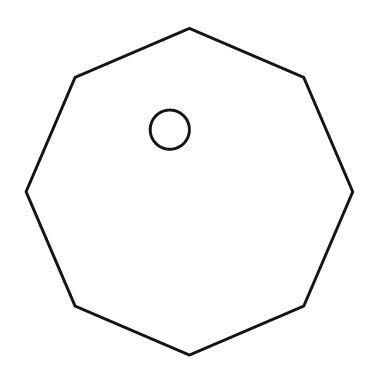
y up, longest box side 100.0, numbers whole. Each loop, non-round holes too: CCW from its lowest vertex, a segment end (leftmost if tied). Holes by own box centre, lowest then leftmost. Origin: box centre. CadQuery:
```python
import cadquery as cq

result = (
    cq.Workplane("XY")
    .moveTo(0.0, -50.0)
    .lineTo(35.0, -35.0)
    .lineTo(50.0, 0.0)
    .lineTo(35.0, 35.0)
    .lineTo(0.0, 50.0)
    .lineTo(-35.0, 35.0)
    .lineTo(-50.0, 0.0)
    .lineTo(-35.0, -35.0)
    .close()
    .moveTo(-6.0, 19.0)
    .circle(6.0)
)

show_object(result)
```